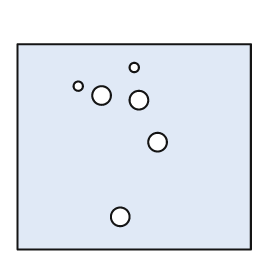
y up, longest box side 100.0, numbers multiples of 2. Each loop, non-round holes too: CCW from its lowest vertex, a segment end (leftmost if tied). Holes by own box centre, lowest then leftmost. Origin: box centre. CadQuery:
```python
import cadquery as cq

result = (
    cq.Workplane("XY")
    .moveTo(-50.0, -44.0)
    .lineTo(50.0, -44.0)
    .lineTo(50.0, 44.0)
    .lineTo(-50.0, 44.0)
    .close()
    .moveTo(-6.0, -30.0)
    .circle(4.0)
    .moveTo(10.0, 2.0)
    .circle(4.0)
    .moveTo(2.0, 20.0)
    .circle(4.0)
    .moveTo(-14.0, 22.0)
    .circle(4.0)
    .moveTo(-24.0, 26.0)
    .circle(2.0)
    .moveTo(0.0, 34.0)
    .circle(2.0)
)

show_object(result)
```